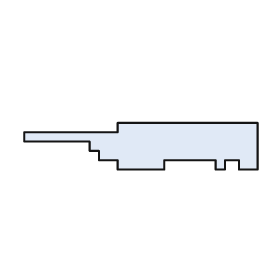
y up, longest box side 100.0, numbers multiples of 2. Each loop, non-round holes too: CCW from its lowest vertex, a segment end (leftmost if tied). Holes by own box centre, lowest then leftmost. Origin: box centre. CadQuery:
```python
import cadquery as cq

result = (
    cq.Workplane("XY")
    .moveTo(-10.0, -10.0)
    .lineTo(10.0, -10.0)
    .lineTo(10.0, -6.0)
    .lineTo(32.0, -6.0)
    .lineTo(32.0, -10.0)
    .lineTo(36.0, -10.0)
    .lineTo(36.0, -6.0)
    .lineTo(42.0, -6.0)
    .lineTo(42.0, -10.0)
    .lineTo(50.0, -10.0)
    .lineTo(50.0, 10.0)
    .lineTo(-10.0, 10.0)
    .lineTo(-10.0, 6.0)
    .lineTo(-50.0, 6.0)
    .lineTo(-50.0, 2.0)
    .lineTo(-22.0, 2.0)
    .lineTo(-22.0, -2.0)
    .lineTo(-18.0, -2.0)
    .lineTo(-18.0, -6.0)
    .lineTo(-10.0, -6.0)
    .close()
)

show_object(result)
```